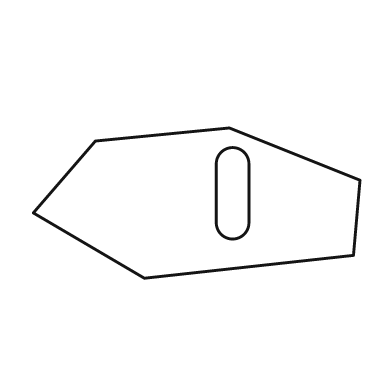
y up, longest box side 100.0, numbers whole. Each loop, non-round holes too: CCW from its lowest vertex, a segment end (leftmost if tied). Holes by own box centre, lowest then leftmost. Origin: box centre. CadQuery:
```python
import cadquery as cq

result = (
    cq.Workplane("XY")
    .moveTo(-16.0, -23.0)
    .lineTo(48.0, -16.0)
    .lineTo(50.0, 7.0)
    .lineTo(10.0, 23.0)
    .lineTo(-31.0, 19.0)
    .lineTo(-50.0, -3.0)
    .close()
    .moveTo(6.0, -6.0)
    .threePointArc((11.0, -11.0), (16.0, -6.0))
    .lineTo(16.0, 12.0)
    .threePointArc((11.0, 17.0), (6.0, 12.0))
    .close()
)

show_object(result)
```